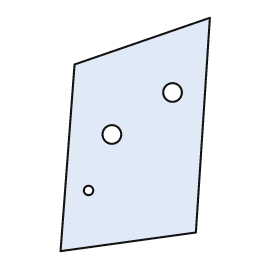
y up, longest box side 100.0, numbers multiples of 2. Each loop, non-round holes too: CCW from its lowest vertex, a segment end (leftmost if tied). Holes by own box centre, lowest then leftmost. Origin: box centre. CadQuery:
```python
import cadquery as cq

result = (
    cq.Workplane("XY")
    .moveTo(-32.0, -50.0)
    .lineTo(26.0, -42.0)
    .lineTo(32.0, 50.0)
    .lineTo(-26.0, 30.0)
    .close()
    .moveTo(-20.0, -24.0)
    .circle(2.0)
    .moveTo(-10.0, 0.0)
    .circle(4.0)
    .moveTo(16.0, 18.0)
    .circle(4.0)
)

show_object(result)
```